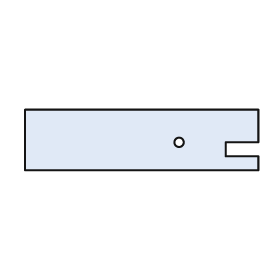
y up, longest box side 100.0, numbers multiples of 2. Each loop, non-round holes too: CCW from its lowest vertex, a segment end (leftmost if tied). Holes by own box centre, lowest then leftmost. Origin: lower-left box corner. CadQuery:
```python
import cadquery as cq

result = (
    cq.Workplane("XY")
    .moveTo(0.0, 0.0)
    .lineTo(100.0, 0.0)
    .lineTo(100.0, 6.0)
    .lineTo(86.0, 6.0)
    .lineTo(86.0, 12.0)
    .lineTo(100.0, 12.0)
    .lineTo(100.0, 26.0)
    .lineTo(0.0, 26.0)
    .close()
    .moveTo(66.0, 12.0)
    .circle(2.0)
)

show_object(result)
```